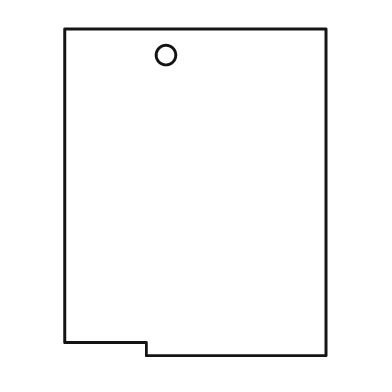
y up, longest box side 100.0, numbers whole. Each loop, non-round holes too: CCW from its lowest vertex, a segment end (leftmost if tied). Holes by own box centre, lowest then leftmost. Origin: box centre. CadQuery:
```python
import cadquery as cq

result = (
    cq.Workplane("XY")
    .moveTo(-15.0, -50.0)
    .lineTo(40.0, -50.0)
    .lineTo(40.0, 50.0)
    .lineTo(-40.0, 50.0)
    .lineTo(-40.0, -46.0)
    .lineTo(-15.0, -46.0)
    .close()
    .moveTo(-9.0, 42.0)
    .circle(3.0)
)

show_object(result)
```